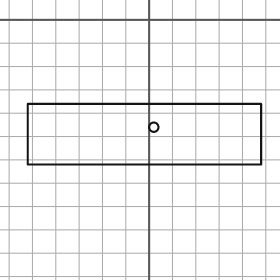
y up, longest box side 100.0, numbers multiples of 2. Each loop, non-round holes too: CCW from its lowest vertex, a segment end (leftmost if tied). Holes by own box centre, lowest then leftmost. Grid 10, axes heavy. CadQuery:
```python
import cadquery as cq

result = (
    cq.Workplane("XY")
    .moveTo(-52.0, -62.0)
    .lineTo(48.0, -62.0)
    .lineTo(48.0, -36.0)
    .lineTo(-52.0, -36.0)
    .close()
    .moveTo(2.0, -46.0)
    .circle(2.0)
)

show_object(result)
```